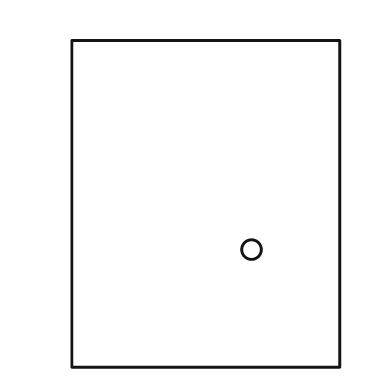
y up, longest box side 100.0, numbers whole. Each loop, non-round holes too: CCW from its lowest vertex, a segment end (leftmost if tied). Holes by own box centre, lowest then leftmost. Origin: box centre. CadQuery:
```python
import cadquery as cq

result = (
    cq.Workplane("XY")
    .moveTo(-41.0, -50.0)
    .lineTo(41.0, -50.0)
    .lineTo(41.0, 50.0)
    .lineTo(-41.0, 50.0)
    .close()
    .moveTo(14.0, -14.0)
    .circle(3.0)
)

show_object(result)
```